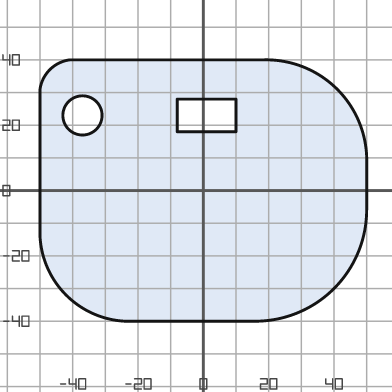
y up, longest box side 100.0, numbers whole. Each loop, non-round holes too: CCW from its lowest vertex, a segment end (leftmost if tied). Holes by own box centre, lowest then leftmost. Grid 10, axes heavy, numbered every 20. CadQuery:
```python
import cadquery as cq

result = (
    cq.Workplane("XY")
    .moveTo(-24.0, -40.0)
    .lineTo(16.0, -40.0)
    .threePointArc((40.0, -30.0), (50.0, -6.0))
    .lineTo(50.0, 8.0)
    .threePointArc((41.0, 31.0), (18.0, 40.0))
    .lineTo(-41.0, 40.0)
    .threePointArc((-47.0, 37.0), (-50.0, 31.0))
    .lineTo(-50.0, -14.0)
    .threePointArc((-42.0, -32.0), (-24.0, -40.0))
    .close()
    .moveTo(-37.0, 23.0)
    .circle(6.0)
    .moveTo(-8.0, 18.0)
    .lineTo(10.0, 18.0)
    .lineTo(10.0, 28.0)
    .lineTo(-8.0, 28.0)
    .close()
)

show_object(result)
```